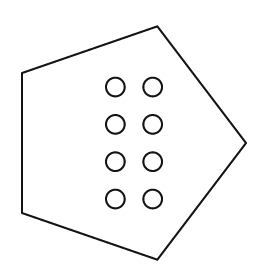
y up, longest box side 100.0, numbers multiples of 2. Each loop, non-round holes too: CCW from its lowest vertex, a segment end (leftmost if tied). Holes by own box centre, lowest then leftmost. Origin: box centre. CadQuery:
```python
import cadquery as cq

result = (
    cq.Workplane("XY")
    .moveTo(10.0, -50.0)
    .lineTo(48.0, 0.0)
    .lineTo(10.0, 50.0)
    .lineTo(-48.0, 30.0)
    .lineTo(-48.0, -30.0)
    .close()
    .moveTo(-8.0, -24.0)
    .circle(4.0)
    .moveTo(8.0, -24.0)
    .circle(4.0)
    .moveTo(-8.0, -8.0)
    .circle(4.0)
    .moveTo(8.0, -8.0)
    .circle(4.0)
    .moveTo(-8.0, 8.0)
    .circle(4.0)
    .moveTo(8.0, 8.0)
    .circle(4.0)
    .moveTo(-8.0, 24.0)
    .circle(4.0)
    .moveTo(8.0, 24.0)
    .circle(4.0)
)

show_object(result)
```